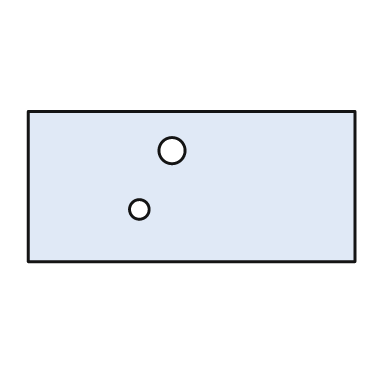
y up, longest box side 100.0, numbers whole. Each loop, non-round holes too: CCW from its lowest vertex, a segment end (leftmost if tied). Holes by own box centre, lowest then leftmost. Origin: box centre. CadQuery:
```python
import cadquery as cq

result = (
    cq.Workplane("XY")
    .moveTo(-50.0, -23.0)
    .lineTo(50.0, -23.0)
    .lineTo(50.0, 23.0)
    .lineTo(-50.0, 23.0)
    .close()
    .moveTo(-16.0, -7.0)
    .circle(3.0)
    .moveTo(-6.0, 11.0)
    .circle(4.0)
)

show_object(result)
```